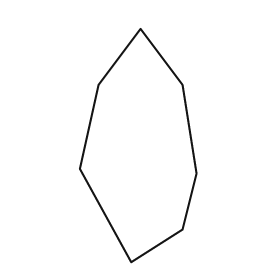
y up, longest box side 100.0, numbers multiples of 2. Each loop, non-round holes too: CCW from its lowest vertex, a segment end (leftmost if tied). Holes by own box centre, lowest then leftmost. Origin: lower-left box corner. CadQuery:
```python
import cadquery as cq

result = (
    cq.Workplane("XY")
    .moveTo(22.0, 0.0)
    .lineTo(44.0, 14.0)
    .lineTo(50.0, 38.0)
    .lineTo(44.0, 76.0)
    .lineTo(26.0, 100.0)
    .lineTo(8.0, 76.0)
    .lineTo(0.0, 40.0)
    .close()
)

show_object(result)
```